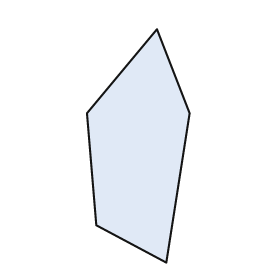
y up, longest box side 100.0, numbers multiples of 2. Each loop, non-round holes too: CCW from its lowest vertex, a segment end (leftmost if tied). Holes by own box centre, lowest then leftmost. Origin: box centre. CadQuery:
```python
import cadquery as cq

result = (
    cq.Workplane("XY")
    .moveTo(12.0, -50.0)
    .lineTo(22.0, 14.0)
    .lineTo(8.0, 50.0)
    .lineTo(-22.0, 14.0)
    .lineTo(-18.0, -34.0)
    .close()
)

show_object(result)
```